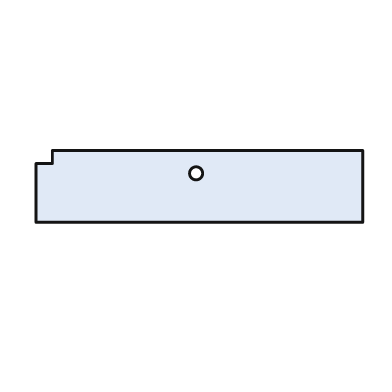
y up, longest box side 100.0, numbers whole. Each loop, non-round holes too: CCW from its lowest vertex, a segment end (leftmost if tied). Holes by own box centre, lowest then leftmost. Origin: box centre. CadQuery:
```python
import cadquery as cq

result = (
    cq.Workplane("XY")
    .moveTo(-50.0, -11.0)
    .lineTo(50.0, -11.0)
    .lineTo(50.0, 11.0)
    .lineTo(-45.0, 11.0)
    .lineTo(-45.0, 7.0)
    .lineTo(-50.0, 7.0)
    .close()
    .moveTo(-1.0, 4.0)
    .circle(2.0)
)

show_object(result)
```